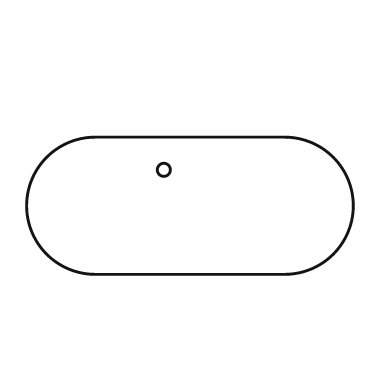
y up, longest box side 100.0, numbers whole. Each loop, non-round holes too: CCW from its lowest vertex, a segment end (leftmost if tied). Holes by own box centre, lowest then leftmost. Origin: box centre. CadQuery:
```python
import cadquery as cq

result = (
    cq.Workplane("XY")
    .moveTo(-29.0, -21.0)
    .lineTo(29.0, -21.0)
    .threePointArc((50.0, 0.0), (29.0, 21.0))
    .lineTo(-29.0, 21.0)
    .threePointArc((-50.0, 0.0), (-29.0, -21.0))
    .close()
    .moveTo(-8.0, 11.0)
    .circle(2.0)
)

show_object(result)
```